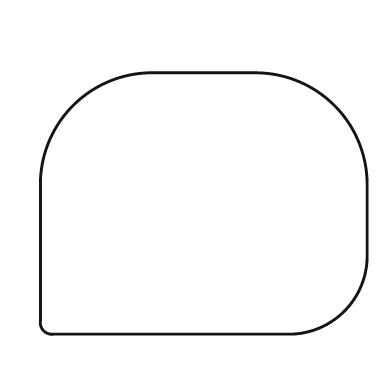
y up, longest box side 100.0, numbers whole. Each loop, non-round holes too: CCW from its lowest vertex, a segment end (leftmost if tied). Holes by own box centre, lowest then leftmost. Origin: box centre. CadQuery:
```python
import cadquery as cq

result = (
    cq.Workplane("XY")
    .moveTo(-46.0, -40.0)
    .lineTo(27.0, -40.0)
    .threePointArc((43.0, -33.0), (50.0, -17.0))
    .lineTo(50.0, 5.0)
    .threePointArc((40.0, 30.0), (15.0, 40.0))
    .lineTo(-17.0, 40.0)
    .threePointArc((-40.0, 30.0), (-50.0, 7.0))
    .lineTo(-50.0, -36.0)
    .threePointArc((-49.0, -39.0), (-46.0, -40.0))
    .close()
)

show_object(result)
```